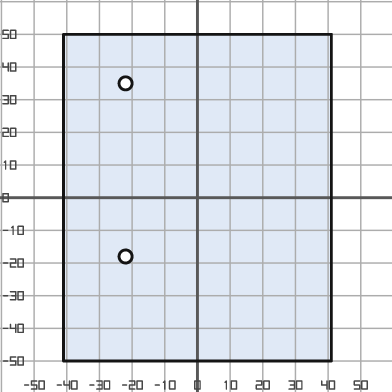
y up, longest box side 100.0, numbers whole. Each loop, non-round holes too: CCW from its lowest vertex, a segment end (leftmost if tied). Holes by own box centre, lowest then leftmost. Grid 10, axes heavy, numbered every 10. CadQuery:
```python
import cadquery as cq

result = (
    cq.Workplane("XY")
    .moveTo(-41.0, -50.0)
    .lineTo(41.0, -50.0)
    .lineTo(41.0, 50.0)
    .lineTo(-41.0, 50.0)
    .close()
    .moveTo(-22.0, -18.0)
    .circle(2.0)
    .moveTo(-22.0, 35.0)
    .circle(2.0)
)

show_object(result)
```